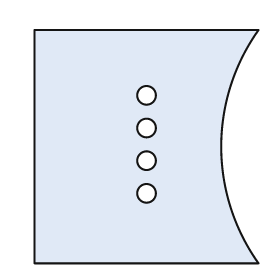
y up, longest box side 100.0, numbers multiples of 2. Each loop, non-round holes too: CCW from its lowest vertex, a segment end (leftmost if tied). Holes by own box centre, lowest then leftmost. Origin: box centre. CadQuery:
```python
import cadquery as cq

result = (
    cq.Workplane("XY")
    .moveTo(-48.0, -50.0)
    .lineTo(48.0, -50.0)
    .threePointArc((32.0, 0.0), (48.0, 50.0))
    .lineTo(-48.0, 50.0)
    .close()
    .moveTo(0.0, -20.0)
    .circle(4.0)
    .moveTo(0.0, -6.0)
    .circle(4.0)
    .moveTo(0.0, 8.0)
    .circle(4.0)
    .moveTo(0.0, 22.0)
    .circle(4.0)
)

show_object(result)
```